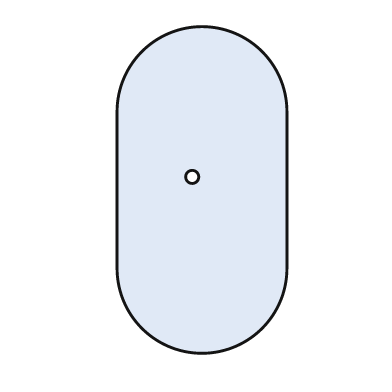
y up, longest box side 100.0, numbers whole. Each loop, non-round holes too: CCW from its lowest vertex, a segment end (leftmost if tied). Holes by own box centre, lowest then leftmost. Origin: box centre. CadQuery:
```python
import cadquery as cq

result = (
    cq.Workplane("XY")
    .moveTo(-26.0, -24.0)
    .threePointArc((0.0, -50.0), (26.0, -24.0))
    .lineTo(26.0, 24.0)
    .threePointArc((0.0, 50.0), (-26.0, 24.0))
    .close()
    .moveTo(-3.0, 4.0)
    .circle(2.0)
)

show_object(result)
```